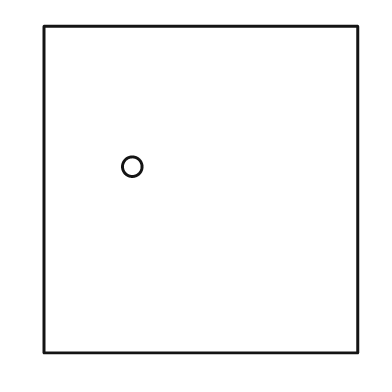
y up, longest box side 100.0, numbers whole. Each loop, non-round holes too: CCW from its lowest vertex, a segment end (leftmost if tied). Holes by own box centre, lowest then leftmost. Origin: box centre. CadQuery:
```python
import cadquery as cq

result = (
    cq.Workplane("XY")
    .moveTo(-48.0, -50.0)
    .lineTo(48.0, -50.0)
    .lineTo(48.0, 50.0)
    .lineTo(-48.0, 50.0)
    .close()
    .moveTo(-21.0, 7.0)
    .circle(3.0)
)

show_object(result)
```